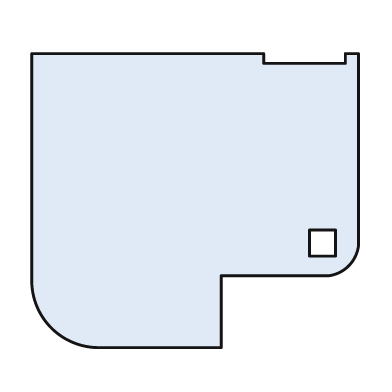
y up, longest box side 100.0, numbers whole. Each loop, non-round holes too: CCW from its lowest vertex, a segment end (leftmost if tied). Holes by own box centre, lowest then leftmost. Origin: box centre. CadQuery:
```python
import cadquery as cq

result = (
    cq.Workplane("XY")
    .moveTo(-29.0, -45.0)
    .lineTo(8.0, -45.0)
    .lineTo(8.0, -23.0)
    .lineTo(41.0, -23.0)
    .threePointArc((47.0, -20.0), (50.0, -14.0))
    .lineTo(50.0, 45.0)
    .lineTo(46.0, 45.0)
    .lineTo(46.0, 42.0)
    .lineTo(21.0, 42.0)
    .lineTo(21.0, 45.0)
    .lineTo(-50.0, 45.0)
    .lineTo(-50.0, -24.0)
    .threePointArc((-44.0, -39.0), (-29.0, -45.0))
    .close()
    .moveTo(35.0, -17.0)
    .lineTo(43.0, -17.0)
    .lineTo(43.0, -9.0)
    .lineTo(35.0, -9.0)
    .close()
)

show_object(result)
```